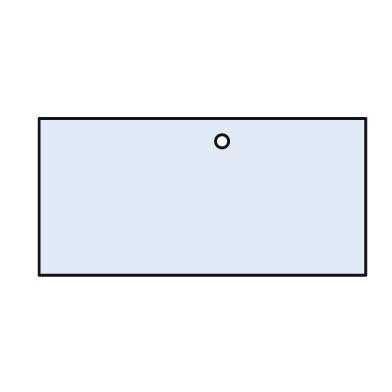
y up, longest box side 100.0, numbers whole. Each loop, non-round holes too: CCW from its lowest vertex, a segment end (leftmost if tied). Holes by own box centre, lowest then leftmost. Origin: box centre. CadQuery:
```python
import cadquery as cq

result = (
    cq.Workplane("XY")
    .moveTo(-50.0, -24.0)
    .lineTo(50.0, -24.0)
    .lineTo(50.0, 24.0)
    .lineTo(-50.0, 24.0)
    .close()
    .moveTo(6.0, 17.0)
    .circle(2.0)
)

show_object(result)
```